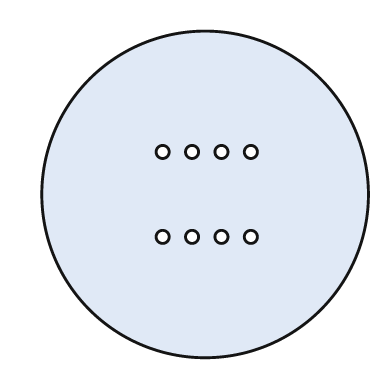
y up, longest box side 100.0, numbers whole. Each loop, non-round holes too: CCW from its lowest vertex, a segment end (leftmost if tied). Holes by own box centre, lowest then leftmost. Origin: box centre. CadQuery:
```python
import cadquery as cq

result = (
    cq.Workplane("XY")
    .moveTo(0.0, 0.0)
    .circle(50.0)
    .moveTo(-13.0, -13.0)
    .circle(2.0)
    .moveTo(-4.0, -13.0)
    .circle(2.0)
    .moveTo(5.0, -13.0)
    .circle(2.0)
    .moveTo(14.0, -13.0)
    .circle(2.0)
    .moveTo(-13.0, 13.0)
    .circle(2.0)
    .moveTo(-4.0, 13.0)
    .circle(2.0)
    .moveTo(5.0, 13.0)
    .circle(2.0)
    .moveTo(14.0, 13.0)
    .circle(2.0)
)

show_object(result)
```